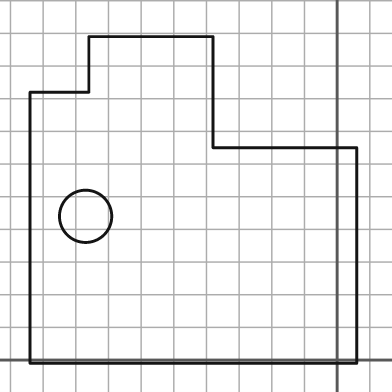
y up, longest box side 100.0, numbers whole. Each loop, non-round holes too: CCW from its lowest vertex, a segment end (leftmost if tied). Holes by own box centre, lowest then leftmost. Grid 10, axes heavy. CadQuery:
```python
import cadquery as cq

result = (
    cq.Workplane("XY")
    .moveTo(-94.0, -1.0)
    .lineTo(6.0, -1.0)
    .lineTo(6.0, 65.0)
    .lineTo(-38.0, 65.0)
    .lineTo(-38.0, 99.0)
    .lineTo(-76.0, 99.0)
    .lineTo(-76.0, 82.0)
    .lineTo(-94.0, 82.0)
    .close()
    .moveTo(-77.0, 44.0)
    .circle(8.0)
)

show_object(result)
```